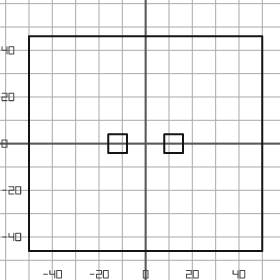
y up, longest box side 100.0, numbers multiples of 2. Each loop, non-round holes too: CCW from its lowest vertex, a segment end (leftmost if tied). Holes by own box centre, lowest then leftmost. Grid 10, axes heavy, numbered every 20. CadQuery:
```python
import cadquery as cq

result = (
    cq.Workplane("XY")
    .moveTo(-50.0, -46.0)
    .lineTo(50.0, -46.0)
    .lineTo(50.0, 46.0)
    .lineTo(-50.0, 46.0)
    .close()
    .moveTo(-16.0, -4.0)
    .lineTo(-8.0, -4.0)
    .lineTo(-8.0, 4.0)
    .lineTo(-16.0, 4.0)
    .close()
    .moveTo(8.0, -4.0)
    .lineTo(16.0, -4.0)
    .lineTo(16.0, 4.0)
    .lineTo(8.0, 4.0)
    .close()
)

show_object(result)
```